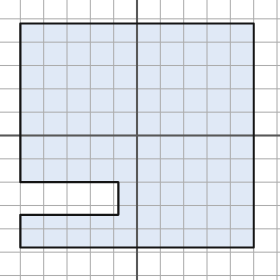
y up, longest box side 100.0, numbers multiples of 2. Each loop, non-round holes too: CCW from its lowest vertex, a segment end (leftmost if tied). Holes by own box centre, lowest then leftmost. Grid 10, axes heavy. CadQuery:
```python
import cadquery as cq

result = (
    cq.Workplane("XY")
    .moveTo(-50.0, -48.0)
    .lineTo(50.0, -48.0)
    .lineTo(50.0, 48.0)
    .lineTo(-50.0, 48.0)
    .lineTo(-50.0, -20.0)
    .lineTo(-8.0, -20.0)
    .lineTo(-8.0, -34.0)
    .lineTo(-50.0, -34.0)
    .close()
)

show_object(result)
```